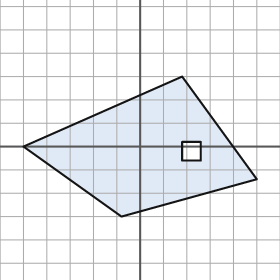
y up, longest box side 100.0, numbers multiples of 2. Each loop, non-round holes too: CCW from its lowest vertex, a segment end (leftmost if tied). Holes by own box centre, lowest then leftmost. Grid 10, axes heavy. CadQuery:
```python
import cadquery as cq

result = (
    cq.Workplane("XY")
    .moveTo(-8.0, -30.0)
    .lineTo(50.0, -14.0)
    .lineTo(18.0, 30.0)
    .lineTo(-50.0, 0.0)
    .close()
    .moveTo(18.0, -6.0)
    .lineTo(26.0, -6.0)
    .lineTo(26.0, 2.0)
    .lineTo(18.0, 2.0)
    .close()
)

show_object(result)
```